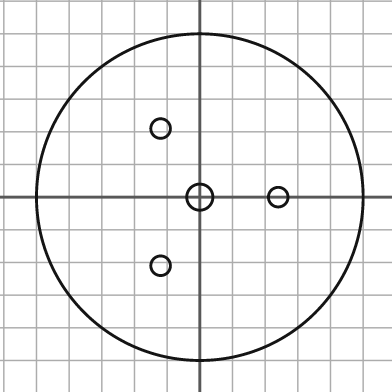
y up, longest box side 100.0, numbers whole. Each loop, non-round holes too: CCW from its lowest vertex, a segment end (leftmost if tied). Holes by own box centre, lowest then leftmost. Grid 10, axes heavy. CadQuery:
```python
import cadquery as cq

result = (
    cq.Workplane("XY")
    .moveTo(0.0, 0.0)
    .circle(50.0)
    .moveTo(-12.0, -21.0)
    .circle(3.0)
    .moveTo(0.0, 0.0)
    .circle(4.0)
    .moveTo(24.0, 0.0)
    .circle(3.0)
    .moveTo(-12.0, 21.0)
    .circle(3.0)
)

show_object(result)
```